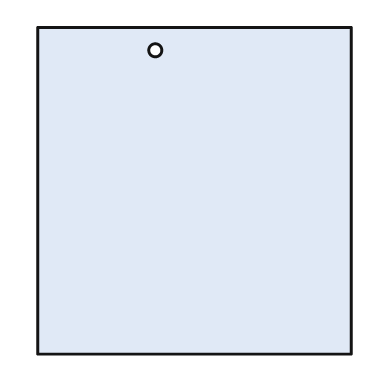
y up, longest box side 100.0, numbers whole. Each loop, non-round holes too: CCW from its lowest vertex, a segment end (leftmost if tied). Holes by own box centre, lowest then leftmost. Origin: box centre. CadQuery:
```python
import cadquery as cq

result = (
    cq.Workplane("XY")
    .moveTo(-48.0, -50.0)
    .lineTo(48.0, -50.0)
    .lineTo(48.0, 50.0)
    .lineTo(-48.0, 50.0)
    .close()
    .moveTo(-12.0, 43.0)
    .circle(2.0)
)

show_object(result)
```